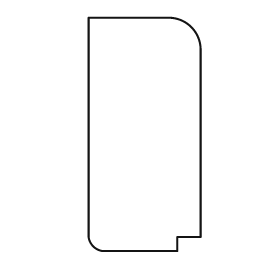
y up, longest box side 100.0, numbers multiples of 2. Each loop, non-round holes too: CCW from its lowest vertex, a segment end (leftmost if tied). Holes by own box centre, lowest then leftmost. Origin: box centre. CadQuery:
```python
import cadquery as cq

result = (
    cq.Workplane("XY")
    .moveTo(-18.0, -50.0)
    .lineTo(14.0, -50.0)
    .lineTo(14.0, -44.0)
    .lineTo(24.0, -44.0)
    .lineTo(24.0, 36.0)
    .threePointArc((20.0, 46.0), (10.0, 50.0))
    .lineTo(-24.0, 50.0)
    .lineTo(-24.0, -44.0)
    .threePointArc((-22.0, -48.0), (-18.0, -50.0))
    .close()
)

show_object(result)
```